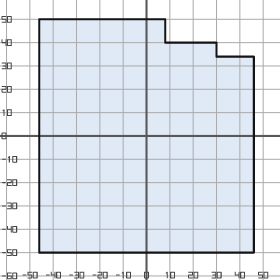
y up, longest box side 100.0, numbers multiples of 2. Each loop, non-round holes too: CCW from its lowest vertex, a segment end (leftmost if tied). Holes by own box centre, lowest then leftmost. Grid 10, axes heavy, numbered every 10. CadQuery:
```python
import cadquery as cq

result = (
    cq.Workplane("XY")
    .moveTo(-46.0, -50.0)
    .lineTo(46.0, -50.0)
    .lineTo(46.0, 34.0)
    .lineTo(30.0, 34.0)
    .lineTo(30.0, 40.0)
    .lineTo(8.0, 40.0)
    .lineTo(8.0, 50.0)
    .lineTo(-46.0, 50.0)
    .close()
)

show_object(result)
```